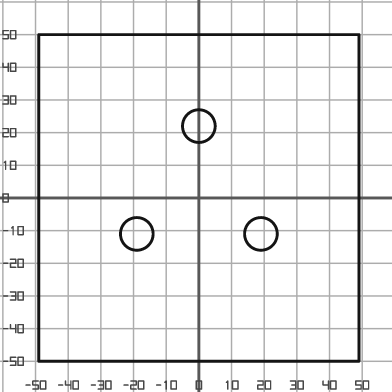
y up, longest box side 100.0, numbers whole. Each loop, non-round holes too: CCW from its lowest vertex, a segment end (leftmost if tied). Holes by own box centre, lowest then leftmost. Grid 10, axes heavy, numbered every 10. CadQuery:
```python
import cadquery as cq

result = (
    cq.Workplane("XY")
    .moveTo(-49.0, -50.0)
    .lineTo(49.0, -50.0)
    .lineTo(49.0, 50.0)
    .lineTo(-49.0, 50.0)
    .close()
    .moveTo(-19.0, -11.0)
    .circle(5.0)
    .moveTo(19.0, -11.0)
    .circle(5.0)
    .moveTo(0.0, 22.0)
    .circle(5.0)
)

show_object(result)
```